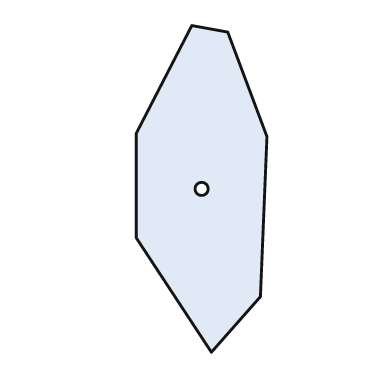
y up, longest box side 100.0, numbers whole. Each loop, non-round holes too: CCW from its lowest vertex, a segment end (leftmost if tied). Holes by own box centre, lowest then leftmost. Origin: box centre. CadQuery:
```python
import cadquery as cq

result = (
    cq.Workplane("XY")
    .moveTo(3.0, -50.0)
    .lineTo(18.0, -33.0)
    .lineTo(20.0, 16.0)
    .lineTo(8.0, 48.0)
    .lineTo(-3.0, 50.0)
    .lineTo(-20.0, 17.0)
    .lineTo(-20.0, -15.0)
    .close()
    .moveTo(0.0, 0.0)
    .circle(2.0)
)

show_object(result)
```